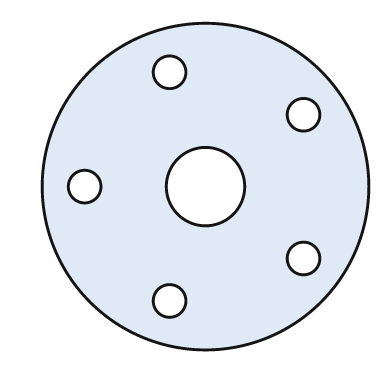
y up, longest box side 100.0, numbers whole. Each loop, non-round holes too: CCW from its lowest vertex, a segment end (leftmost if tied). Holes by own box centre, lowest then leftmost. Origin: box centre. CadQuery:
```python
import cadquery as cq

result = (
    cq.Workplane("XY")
    .moveTo(0.0, 0.0)
    .circle(50.0)
    .moveTo(-11.0, -35.0)
    .circle(5.0)
    .moveTo(30.0, -22.0)
    .circle(5.0)
    .moveTo(-37.0, 0.0)
    .circle(5.0)
    .moveTo(0.0, 0.0)
    .circle(12.0)
    .moveTo(30.0, 22.0)
    .circle(5.0)
    .moveTo(-11.0, 35.0)
    .circle(5.0)
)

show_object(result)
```